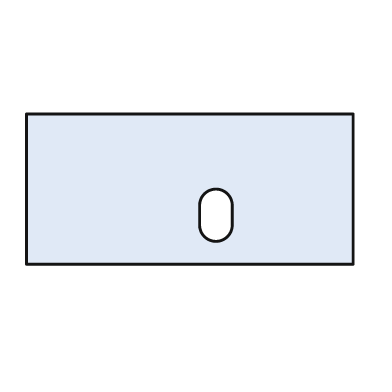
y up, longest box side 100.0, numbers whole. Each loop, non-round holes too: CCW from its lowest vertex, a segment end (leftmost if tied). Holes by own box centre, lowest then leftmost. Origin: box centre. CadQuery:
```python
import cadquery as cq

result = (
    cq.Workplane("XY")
    .moveTo(-50.0, -23.0)
    .lineTo(50.0, -23.0)
    .lineTo(50.0, 23.0)
    .lineTo(-50.0, 23.0)
    .close()
    .moveTo(3.0, -11.0)
    .threePointArc((8.0, -16.0), (13.0, -11.0))
    .lineTo(13.0, -5.0)
    .threePointArc((8.0, 0.0), (3.0, -5.0))
    .close()
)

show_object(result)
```